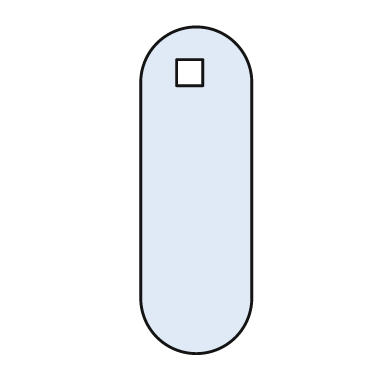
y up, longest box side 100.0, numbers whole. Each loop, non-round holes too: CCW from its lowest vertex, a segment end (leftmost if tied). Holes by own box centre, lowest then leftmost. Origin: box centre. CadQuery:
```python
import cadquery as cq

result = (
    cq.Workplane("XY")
    .moveTo(-17.0, -33.0)
    .threePointArc((0.0, -50.0), (17.0, -33.0))
    .lineTo(17.0, 33.0)
    .threePointArc((0.0, 50.0), (-17.0, 33.0))
    .close()
    .moveTo(-6.0, 32.0)
    .lineTo(2.0, 32.0)
    .lineTo(2.0, 40.0)
    .lineTo(-6.0, 40.0)
    .close()
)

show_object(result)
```